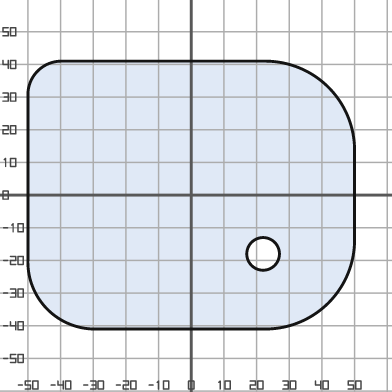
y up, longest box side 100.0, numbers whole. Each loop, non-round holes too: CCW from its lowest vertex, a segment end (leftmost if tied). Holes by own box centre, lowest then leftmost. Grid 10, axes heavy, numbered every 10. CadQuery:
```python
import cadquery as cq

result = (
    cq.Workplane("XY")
    .moveTo(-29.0, -41.0)
    .lineTo(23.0, -41.0)
    .threePointArc((42.0, -33.0), (50.0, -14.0))
    .lineTo(50.0, 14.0)
    .threePointArc((42.0, 33.0), (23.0, 41.0))
    .lineTo(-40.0, 41.0)
    .threePointArc((-47.0, 38.0), (-50.0, 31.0))
    .lineTo(-50.0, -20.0)
    .threePointArc((-44.0, -35.0), (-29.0, -41.0))
    .close()
    .moveTo(22.0, -18.0)
    .circle(5.0)
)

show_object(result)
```